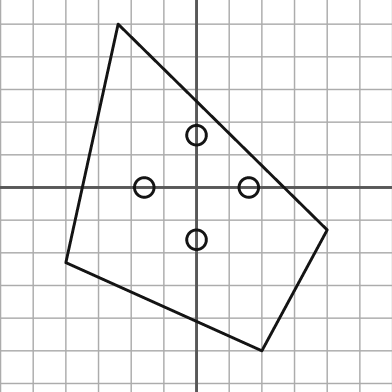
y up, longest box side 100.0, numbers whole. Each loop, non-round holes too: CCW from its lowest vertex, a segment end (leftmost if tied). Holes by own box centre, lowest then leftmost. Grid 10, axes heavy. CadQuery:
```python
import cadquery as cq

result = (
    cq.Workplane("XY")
    .moveTo(20.0, -50.0)
    .lineTo(40.0, -13.0)
    .lineTo(-24.0, 50.0)
    .lineTo(-40.0, -23.0)
    .close()
    .moveTo(0.0, -16.0)
    .circle(3.0)
    .moveTo(-16.0, 0.0)
    .circle(3.0)
    .moveTo(16.0, 0.0)
    .circle(3.0)
    .moveTo(0.0, 16.0)
    .circle(3.0)
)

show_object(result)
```